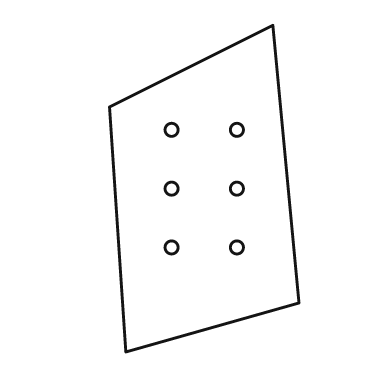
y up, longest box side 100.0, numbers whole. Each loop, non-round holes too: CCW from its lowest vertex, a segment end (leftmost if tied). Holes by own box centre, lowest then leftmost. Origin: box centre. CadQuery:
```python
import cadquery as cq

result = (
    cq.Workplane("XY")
    .moveTo(-24.0, -50.0)
    .lineTo(29.0, -35.0)
    .lineTo(21.0, 50.0)
    .lineTo(-29.0, 25.0)
    .close()
    .moveTo(-10.0, -18.0)
    .circle(2.0)
    .moveTo(10.0, -18.0)
    .circle(2.0)
    .moveTo(-10.0, 0.0)
    .circle(2.0)
    .moveTo(10.0, 0.0)
    .circle(2.0)
    .moveTo(-10.0, 18.0)
    .circle(2.0)
    .moveTo(10.0, 18.0)
    .circle(2.0)
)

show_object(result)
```